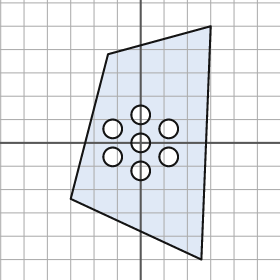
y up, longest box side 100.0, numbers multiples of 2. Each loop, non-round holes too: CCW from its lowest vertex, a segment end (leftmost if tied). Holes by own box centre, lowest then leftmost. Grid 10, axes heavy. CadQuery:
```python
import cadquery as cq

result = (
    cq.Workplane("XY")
    .moveTo(26.0, -50.0)
    .lineTo(30.0, 50.0)
    .lineTo(-14.0, 38.0)
    .lineTo(-30.0, -24.0)
    .close()
    .moveTo(0.0, -12.0)
    .circle(4.0)
    .moveTo(-12.0, -6.0)
    .circle(4.0)
    .moveTo(12.0, -6.0)
    .circle(4.0)
    .moveTo(0.0, 0.0)
    .circle(4.0)
    .moveTo(-12.0, 6.0)
    .circle(4.0)
    .moveTo(12.0, 6.0)
    .circle(4.0)
    .moveTo(0.0, 12.0)
    .circle(4.0)
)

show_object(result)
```